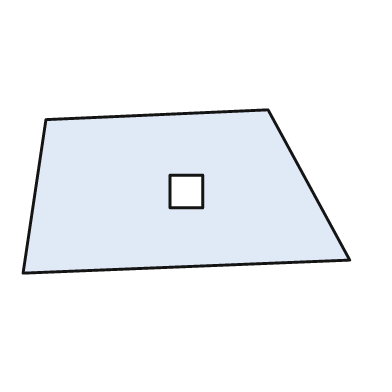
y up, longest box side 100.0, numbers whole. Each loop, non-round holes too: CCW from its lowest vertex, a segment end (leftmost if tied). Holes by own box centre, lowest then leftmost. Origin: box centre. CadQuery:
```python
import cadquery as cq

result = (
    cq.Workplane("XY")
    .moveTo(-50.0, -25.0)
    .lineTo(50.0, -21.0)
    .lineTo(25.0, 25.0)
    .lineTo(-43.0, 22.0)
    .close()
    .moveTo(-5.0, -5.0)
    .lineTo(5.0, -5.0)
    .lineTo(5.0, 5.0)
    .lineTo(-5.0, 5.0)
    .close()
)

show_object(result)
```